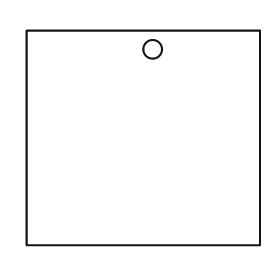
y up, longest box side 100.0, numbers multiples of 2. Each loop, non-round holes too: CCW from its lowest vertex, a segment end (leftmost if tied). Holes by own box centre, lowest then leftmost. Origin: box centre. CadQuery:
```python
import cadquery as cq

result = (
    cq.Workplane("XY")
    .moveTo(-50.0, -46.0)
    .lineTo(50.0, -46.0)
    .lineTo(50.0, 46.0)
    .lineTo(-50.0, 46.0)
    .close()
    .moveTo(4.0, 38.0)
    .circle(4.0)
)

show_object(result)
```